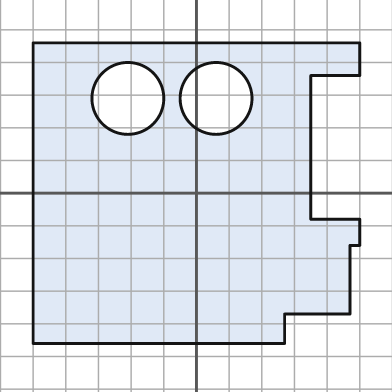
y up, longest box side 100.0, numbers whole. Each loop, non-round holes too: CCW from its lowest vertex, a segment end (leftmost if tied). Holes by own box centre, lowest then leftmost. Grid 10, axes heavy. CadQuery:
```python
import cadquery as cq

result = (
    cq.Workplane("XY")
    .moveTo(-50.0, -46.0)
    .lineTo(27.0, -46.0)
    .lineTo(27.0, -37.0)
    .lineTo(47.0, -37.0)
    .lineTo(47.0, -16.0)
    .lineTo(50.0, -16.0)
    .lineTo(50.0, -8.0)
    .lineTo(35.0, -8.0)
    .lineTo(35.0, 36.0)
    .lineTo(50.0, 36.0)
    .lineTo(50.0, 46.0)
    .lineTo(-50.0, 46.0)
    .close()
    .moveTo(-21.0, 29.0)
    .circle(11.0)
    .moveTo(6.0, 29.0)
    .circle(11.0)
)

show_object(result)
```